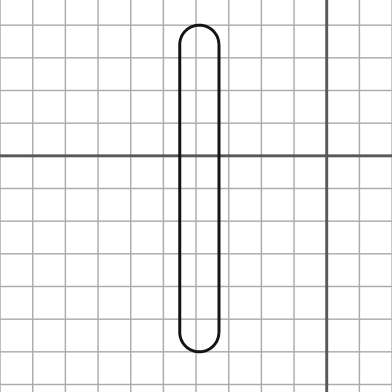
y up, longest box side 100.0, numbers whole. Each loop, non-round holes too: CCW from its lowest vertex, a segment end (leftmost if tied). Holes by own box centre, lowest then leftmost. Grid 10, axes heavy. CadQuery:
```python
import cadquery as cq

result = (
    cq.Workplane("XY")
    .moveTo(-45.0, -54.0)
    .threePointArc((-39.0, -60.0), (-33.0, -54.0))
    .lineTo(-33.0, 34.0)
    .threePointArc((-39.0, 40.0), (-45.0, 34.0))
    .close()
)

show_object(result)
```